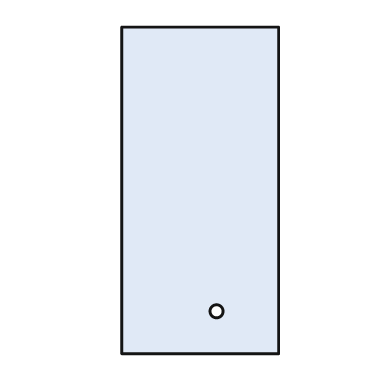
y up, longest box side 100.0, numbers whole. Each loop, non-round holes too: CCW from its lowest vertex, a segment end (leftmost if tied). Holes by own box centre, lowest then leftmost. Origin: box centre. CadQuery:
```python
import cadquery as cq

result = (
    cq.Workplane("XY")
    .moveTo(-24.0, -50.0)
    .lineTo(24.0, -50.0)
    .lineTo(24.0, 50.0)
    .lineTo(-24.0, 50.0)
    .close()
    .moveTo(5.0, -37.0)
    .circle(2.0)
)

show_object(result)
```